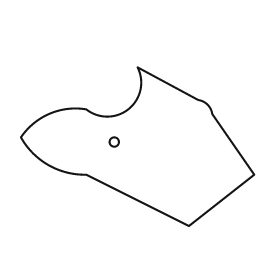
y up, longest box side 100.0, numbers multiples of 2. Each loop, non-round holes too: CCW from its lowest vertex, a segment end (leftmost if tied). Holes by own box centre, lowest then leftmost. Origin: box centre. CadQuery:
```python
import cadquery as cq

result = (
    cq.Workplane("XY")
    .moveTo(22.0, -34.0)
    .lineTo(50.0, -12.0)
    .lineTo(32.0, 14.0)
    .threePointArc((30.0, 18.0), (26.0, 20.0))
    .lineTo(0.0, 34.0)
    .threePointArc((-4.0, 16.0), (-22.0, 16.0))
    .threePointArc((-38.0, 14.0), (-50.0, 4.0))
    .threePointArc((-38.0, -8.0), (-22.0, -12.0))
    .close()
    .moveTo(-10.0, 2.0)
    .circle(2.0)
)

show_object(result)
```